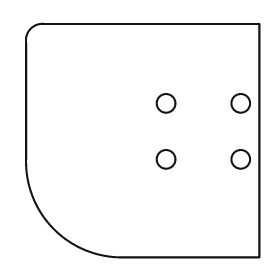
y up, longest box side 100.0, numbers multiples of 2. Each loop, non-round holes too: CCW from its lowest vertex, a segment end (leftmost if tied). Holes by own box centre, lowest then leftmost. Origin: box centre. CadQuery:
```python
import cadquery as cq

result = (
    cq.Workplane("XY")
    .moveTo(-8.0, -50.0)
    .lineTo(50.0, -50.0)
    .lineTo(50.0, 50.0)
    .lineTo(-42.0, 50.0)
    .threePointArc((-48.0, 48.0), (-50.0, 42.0))
    .lineTo(-50.0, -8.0)
    .threePointArc((-38.0, -38.0), (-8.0, -50.0))
    .close()
    .moveTo(10.0, -8.0)
    .circle(4.0)
    .moveTo(42.0, -8.0)
    .circle(4.0)
    .moveTo(10.0, 16.0)
    .circle(4.0)
    .moveTo(42.0, 16.0)
    .circle(4.0)
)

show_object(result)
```